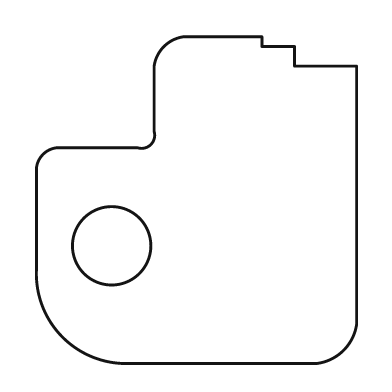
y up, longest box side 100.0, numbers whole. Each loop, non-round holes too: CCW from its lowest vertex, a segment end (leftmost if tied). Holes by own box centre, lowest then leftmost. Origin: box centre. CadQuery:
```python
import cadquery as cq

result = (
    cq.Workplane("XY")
    .moveTo(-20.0, -50.0)
    .lineTo(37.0, -50.0)
    .threePointArc((45.0, -46.0), (49.0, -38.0))
    .lineTo(49.0, 41.0)
    .lineTo(30.0, 41.0)
    .lineTo(30.0, 47.0)
    .lineTo(20.0, 47.0)
    .lineTo(20.0, 50.0)
    .lineTo(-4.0, 50.0)
    .threePointArc((-10.0, 47.0), (-13.0, 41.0))
    .lineTo(-13.0, 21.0)
    .threePointArc((-14.0, 17.0), (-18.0, 16.0))
    .lineTo(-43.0, 16.0)
    .threePointArc((-47.0, 14.0), (-49.0, 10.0))
    .lineTo(-49.0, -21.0)
    .threePointArc((-41.0, -42.0), (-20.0, -50.0))
    .close()
    .moveTo(-26.0, -14.0)
    .circle(12.0)
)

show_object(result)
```